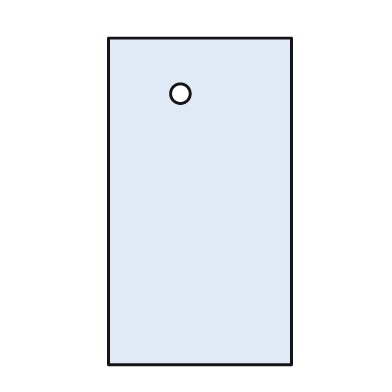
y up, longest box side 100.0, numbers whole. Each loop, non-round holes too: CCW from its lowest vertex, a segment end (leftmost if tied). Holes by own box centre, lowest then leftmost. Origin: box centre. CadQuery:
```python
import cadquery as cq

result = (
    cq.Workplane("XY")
    .moveTo(-28.0, -50.0)
    .lineTo(28.0, -50.0)
    .lineTo(28.0, 50.0)
    .lineTo(-28.0, 50.0)
    .close()
    .moveTo(-6.0, 33.0)
    .circle(3.0)
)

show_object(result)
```